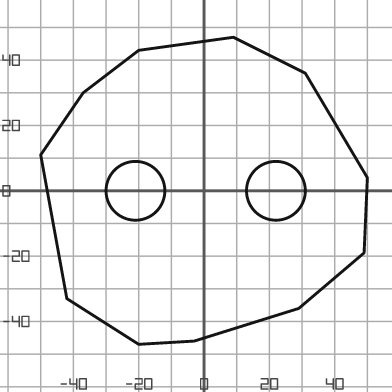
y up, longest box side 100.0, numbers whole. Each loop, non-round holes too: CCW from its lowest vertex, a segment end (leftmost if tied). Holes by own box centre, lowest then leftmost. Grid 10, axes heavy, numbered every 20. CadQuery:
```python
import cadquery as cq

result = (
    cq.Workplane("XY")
    .moveTo(-20.0, -47.0)
    .lineTo(-3.0, -46.0)
    .lineTo(29.0, -36.0)
    .lineTo(49.0, -19.0)
    .lineTo(50.0, 4.0)
    .lineTo(31.0, 36.0)
    .lineTo(9.0, 47.0)
    .lineTo(-20.0, 43.0)
    .lineTo(-37.0, 30.0)
    .lineTo(-50.0, 11.0)
    .lineTo(-42.0, -33.0)
    .close()
    .moveTo(-21.0, 0.0)
    .circle(9.0)
    .moveTo(22.0, 0.0)
    .circle(9.0)
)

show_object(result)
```